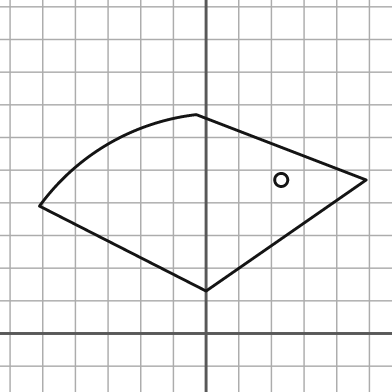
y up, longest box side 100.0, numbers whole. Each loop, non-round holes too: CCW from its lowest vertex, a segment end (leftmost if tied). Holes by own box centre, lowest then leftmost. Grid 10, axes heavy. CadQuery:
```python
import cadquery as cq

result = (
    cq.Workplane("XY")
    .moveTo(0.0, 13.0)
    .lineTo(49.0, 47.0)
    .lineTo(-3.0, 67.0)
    .threePointArc((-30.0, 58.0), (-51.0, 39.0))
    .close()
    .moveTo(23.0, 47.0)
    .circle(2.0)
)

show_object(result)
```